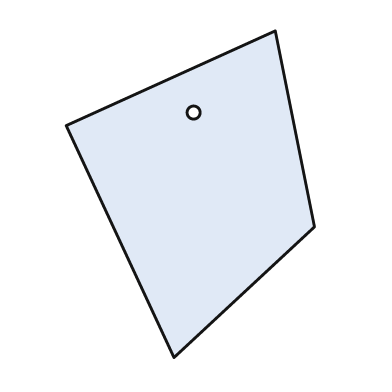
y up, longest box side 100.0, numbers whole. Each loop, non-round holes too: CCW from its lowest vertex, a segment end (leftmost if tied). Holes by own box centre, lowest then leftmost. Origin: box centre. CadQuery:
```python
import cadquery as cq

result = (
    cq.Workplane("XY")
    .moveTo(-5.0, -50.0)
    .lineTo(38.0, -10.0)
    .lineTo(26.0, 50.0)
    .lineTo(-38.0, 21.0)
    .close()
    .moveTo(1.0, 25.0)
    .circle(2.0)
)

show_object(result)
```